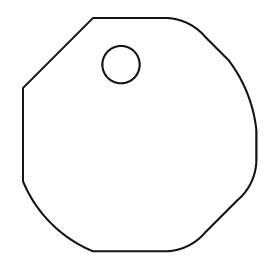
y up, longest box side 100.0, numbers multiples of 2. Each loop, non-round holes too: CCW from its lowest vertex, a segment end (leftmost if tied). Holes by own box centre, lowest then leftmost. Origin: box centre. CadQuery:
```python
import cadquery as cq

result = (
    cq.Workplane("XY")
    .moveTo(-20.0, -50.0)
    .lineTo(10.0, -50.0)
    .threePointArc((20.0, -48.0), (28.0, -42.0))
    .lineTo(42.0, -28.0)
    .threePointArc((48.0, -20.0), (50.0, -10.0))
    .lineTo(50.0, 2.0)
    .threePointArc((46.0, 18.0), (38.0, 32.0))
    .lineTo(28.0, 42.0)
    .threePointArc((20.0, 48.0), (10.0, 50.0))
    .lineTo(-20.0, 50.0)
    .lineTo(-50.0, 20.0)
    .lineTo(-50.0, -20.0)
    .threePointArc((-38.0, -38.0), (-20.0, -50.0))
    .close()
    .moveTo(-8.0, 30.0)
    .circle(8.0)
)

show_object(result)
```